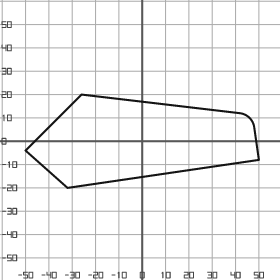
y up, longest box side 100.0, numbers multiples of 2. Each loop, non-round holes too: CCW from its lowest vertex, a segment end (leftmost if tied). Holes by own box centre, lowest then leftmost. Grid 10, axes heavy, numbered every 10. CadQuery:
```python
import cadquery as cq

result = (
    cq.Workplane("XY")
    .moveTo(-32.0, -20.0)
    .lineTo(50.0, -8.0)
    .lineTo(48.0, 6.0)
    .threePointArc((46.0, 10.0), (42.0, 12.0))
    .lineTo(-26.0, 20.0)
    .lineTo(-50.0, -4.0)
    .close()
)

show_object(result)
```